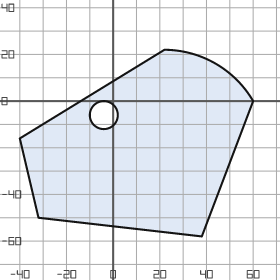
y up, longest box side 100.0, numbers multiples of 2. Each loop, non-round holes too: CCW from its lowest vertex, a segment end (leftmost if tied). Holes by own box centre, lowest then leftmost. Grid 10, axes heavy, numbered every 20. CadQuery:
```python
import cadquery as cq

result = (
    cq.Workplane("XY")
    .moveTo(38.0, -58.0)
    .lineTo(60.0, 0.0)
    .threePointArc((44.0, 16.0), (22.0, 22.0))
    .lineTo(-40.0, -16.0)
    .lineTo(-32.0, -50.0)
    .close()
    .moveTo(-4.0, -6.0)
    .circle(6.0)
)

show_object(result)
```